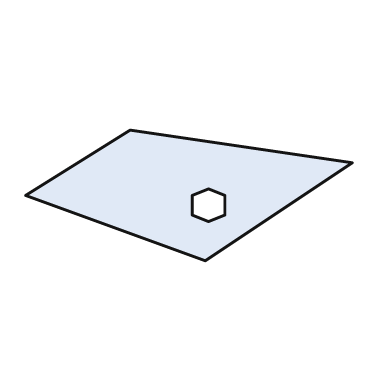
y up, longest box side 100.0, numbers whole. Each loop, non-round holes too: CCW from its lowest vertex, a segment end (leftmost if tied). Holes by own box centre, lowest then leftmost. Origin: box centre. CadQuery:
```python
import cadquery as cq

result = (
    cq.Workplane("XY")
    .moveTo(5.0, -20.0)
    .lineTo(50.0, 10.0)
    .lineTo(-18.0, 20.0)
    .lineTo(-50.0, 0.0)
    .close()
    .moveTo(6.0, -8.0)
    .lineTo(11.0, -6.0)
    .lineTo(11.0, 0.0)
    .lineTo(6.0, 2.0)
    .lineTo(1.0, 0.0)
    .lineTo(1.0, -6.0)
    .close()
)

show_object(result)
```